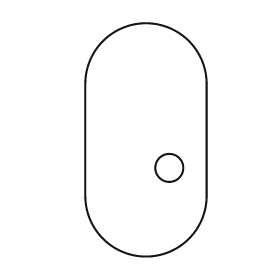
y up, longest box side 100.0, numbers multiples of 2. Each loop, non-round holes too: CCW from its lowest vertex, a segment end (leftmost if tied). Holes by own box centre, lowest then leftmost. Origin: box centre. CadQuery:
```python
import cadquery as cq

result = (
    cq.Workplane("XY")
    .moveTo(-26.0, -24.0)
    .threePointArc((0.0, -50.0), (26.0, -24.0))
    .lineTo(26.0, 24.0)
    .threePointArc((0.0, 50.0), (-26.0, 24.0))
    .close()
    .moveTo(10.0, -12.0)
    .circle(6.0)
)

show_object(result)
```